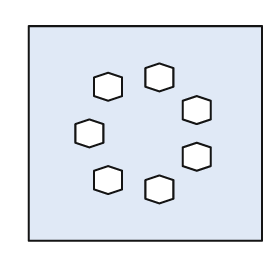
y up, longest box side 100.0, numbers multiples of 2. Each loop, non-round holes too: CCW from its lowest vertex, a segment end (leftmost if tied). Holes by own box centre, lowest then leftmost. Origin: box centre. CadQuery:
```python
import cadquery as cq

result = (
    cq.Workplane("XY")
    .moveTo(-50.0, -46.0)
    .lineTo(50.0, -46.0)
    .lineTo(50.0, 46.0)
    .lineTo(-50.0, 46.0)
    .close()
    .moveTo(6.0, -30.0)
    .lineTo(12.0, -28.0)
    .lineTo(12.0, -20.0)
    .lineTo(6.0, -18.0)
    .lineTo(0.0, -20.0)
    .lineTo(0.0, -28.0)
    .close()
    .moveTo(-16.0, -26.0)
    .lineTo(-10.0, -24.0)
    .lineTo(-10.0, -16.0)
    .lineTo(-16.0, -14.0)
    .lineTo(-22.0, -16.0)
    .lineTo(-22.0, -24.0)
    .close()
    .moveTo(22.0, -16.0)
    .lineTo(28.0, -14.0)
    .lineTo(28.0, -6.0)
    .lineTo(22.0, -4.0)
    .lineTo(16.0, -6.0)
    .lineTo(16.0, -14.0)
    .close()
    .moveTo(-24.0, -6.0)
    .lineTo(-18.0, -4.0)
    .lineTo(-18.0, 4.0)
    .lineTo(-24.0, 6.0)
    .lineTo(-30.0, 4.0)
    .lineTo(-30.0, -4.0)
    .close()
    .moveTo(22.0, 4.0)
    .lineTo(28.0, 6.0)
    .lineTo(28.0, 14.0)
    .lineTo(22.0, 16.0)
    .lineTo(16.0, 14.0)
    .lineTo(16.0, 6.0)
    .close()
    .moveTo(-16.0, 14.0)
    .lineTo(-10.0, 16.0)
    .lineTo(-10.0, 24.0)
    .lineTo(-16.0, 26.0)
    .lineTo(-22.0, 24.0)
    .lineTo(-22.0, 16.0)
    .close()
    .moveTo(6.0, 18.0)
    .lineTo(12.0, 20.0)
    .lineTo(12.0, 28.0)
    .lineTo(6.0, 30.0)
    .lineTo(0.0, 28.0)
    .lineTo(0.0, 20.0)
    .close()
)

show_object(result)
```